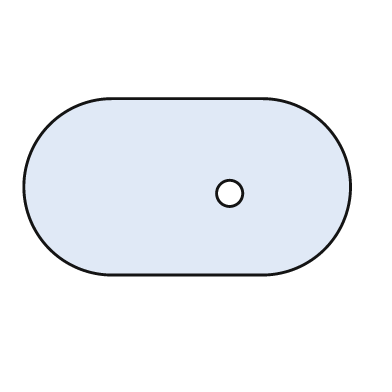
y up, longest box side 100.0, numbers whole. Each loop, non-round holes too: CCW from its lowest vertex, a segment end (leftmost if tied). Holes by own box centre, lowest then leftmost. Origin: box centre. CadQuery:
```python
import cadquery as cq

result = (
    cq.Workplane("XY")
    .moveTo(-23.0, -27.0)
    .lineTo(23.0, -27.0)
    .threePointArc((50.0, 0.0), (23.0, 27.0))
    .lineTo(-23.0, 27.0)
    .threePointArc((-50.0, 0.0), (-23.0, -27.0))
    .close()
    .moveTo(13.0, -2.0)
    .circle(4.0)
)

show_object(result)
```